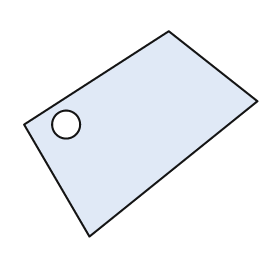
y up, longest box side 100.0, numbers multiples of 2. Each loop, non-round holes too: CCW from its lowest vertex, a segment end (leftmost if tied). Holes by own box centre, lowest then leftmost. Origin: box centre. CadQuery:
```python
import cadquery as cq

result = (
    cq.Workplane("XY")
    .moveTo(-22.0, -44.0)
    .lineTo(50.0, 14.0)
    .lineTo(12.0, 44.0)
    .lineTo(-50.0, 4.0)
    .close()
    .moveTo(-32.0, 4.0)
    .circle(6.0)
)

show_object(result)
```